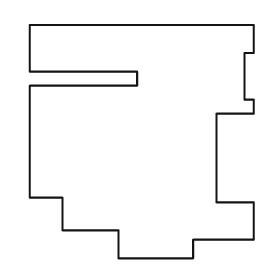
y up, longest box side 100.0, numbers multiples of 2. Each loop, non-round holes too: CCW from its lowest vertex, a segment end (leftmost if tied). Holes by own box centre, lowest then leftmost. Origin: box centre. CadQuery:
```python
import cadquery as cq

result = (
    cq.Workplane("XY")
    .moveTo(-10.0, -50.0)
    .lineTo(22.0, -50.0)
    .lineTo(22.0, -42.0)
    .lineTo(48.0, -42.0)
    .lineTo(48.0, -26.0)
    .lineTo(32.0, -26.0)
    .lineTo(32.0, 12.0)
    .lineTo(48.0, 12.0)
    .lineTo(48.0, 18.0)
    .lineTo(44.0, 18.0)
    .lineTo(44.0, 38.0)
    .lineTo(48.0, 38.0)
    .lineTo(48.0, 50.0)
    .lineTo(-48.0, 50.0)
    .lineTo(-48.0, 30.0)
    .lineTo(-2.0, 30.0)
    .lineTo(-2.0, 24.0)
    .lineTo(-48.0, 24.0)
    .lineTo(-48.0, -24.0)
    .lineTo(-34.0, -24.0)
    .lineTo(-34.0, -38.0)
    .lineTo(-10.0, -38.0)
    .close()
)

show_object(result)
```